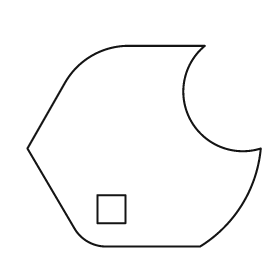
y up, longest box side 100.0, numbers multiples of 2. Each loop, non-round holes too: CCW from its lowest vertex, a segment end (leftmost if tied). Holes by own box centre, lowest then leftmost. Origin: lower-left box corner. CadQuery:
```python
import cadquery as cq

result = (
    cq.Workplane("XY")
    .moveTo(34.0, 0.0)
    .lineTo(74.0, 0.0)
    .threePointArc((92.0, 18.0), (100.0, 42.0))
    .threePointArc((70.0, 54.0), (76.0, 86.0))
    .lineTo(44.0, 86.0)
    .threePointArc((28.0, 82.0), (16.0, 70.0))
    .lineTo(0.0, 42.0)
    .lineTo(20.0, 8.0)
    .threePointArc((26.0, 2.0), (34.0, 0.0))
    .close()
    .moveTo(30.0, 10.0)
    .lineTo(42.0, 10.0)
    .lineTo(42.0, 22.0)
    .lineTo(30.0, 22.0)
    .close()
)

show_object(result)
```